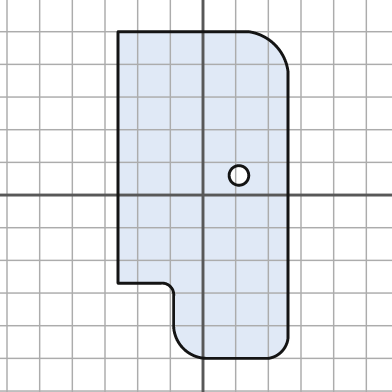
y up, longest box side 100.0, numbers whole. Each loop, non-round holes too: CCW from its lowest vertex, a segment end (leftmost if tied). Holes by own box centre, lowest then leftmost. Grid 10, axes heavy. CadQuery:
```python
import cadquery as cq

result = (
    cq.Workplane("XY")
    .moveTo(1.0, -50.0)
    .lineTo(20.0, -50.0)
    .threePointArc((24.0, -48.0), (26.0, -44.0))
    .lineTo(26.0, 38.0)
    .threePointArc((22.0, 46.0), (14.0, 50.0))
    .lineTo(-26.0, 50.0)
    .lineTo(-26.0, -27.0)
    .lineTo(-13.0, -27.0)
    .threePointArc((-10.0, -28.0), (-9.0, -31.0))
    .lineTo(-9.0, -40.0)
    .threePointArc((-6.0, -47.0), (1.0, -50.0))
    .close()
    .moveTo(11.0, 6.0)
    .circle(3.0)
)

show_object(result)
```